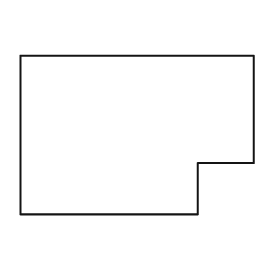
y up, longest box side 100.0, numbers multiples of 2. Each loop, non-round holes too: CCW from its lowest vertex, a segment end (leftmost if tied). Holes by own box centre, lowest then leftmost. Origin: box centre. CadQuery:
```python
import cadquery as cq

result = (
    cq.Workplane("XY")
    .moveTo(-50.0, -34.0)
    .lineTo(26.0, -34.0)
    .lineTo(26.0, -12.0)
    .lineTo(50.0, -12.0)
    .lineTo(50.0, 34.0)
    .lineTo(-50.0, 34.0)
    .close()
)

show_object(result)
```